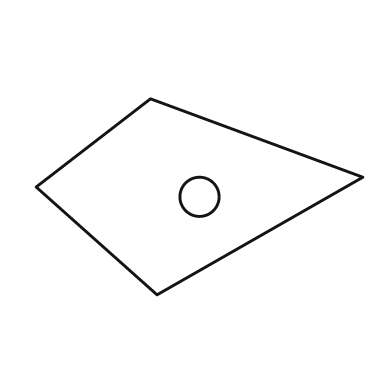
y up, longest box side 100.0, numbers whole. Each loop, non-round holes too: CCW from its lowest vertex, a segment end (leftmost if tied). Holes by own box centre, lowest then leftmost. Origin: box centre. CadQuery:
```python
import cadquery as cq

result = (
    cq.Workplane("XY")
    .moveTo(-13.0, -30.0)
    .lineTo(50.0, 6.0)
    .lineTo(-15.0, 30.0)
    .lineTo(-50.0, 3.0)
    .close()
    .moveTo(0.0, 0.0)
    .circle(6.0)
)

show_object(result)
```